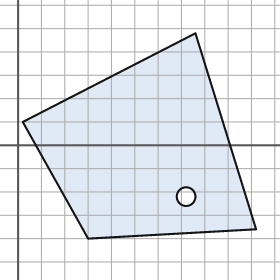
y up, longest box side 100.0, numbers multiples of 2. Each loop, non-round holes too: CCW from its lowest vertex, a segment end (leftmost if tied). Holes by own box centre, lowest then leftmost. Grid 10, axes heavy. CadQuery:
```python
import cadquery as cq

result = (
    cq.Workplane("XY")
    .moveTo(30.0, -40.0)
    .lineTo(102.0, -36.0)
    .lineTo(76.0, 48.0)
    .lineTo(2.0, 10.0)
    .close()
    .moveTo(72.0, -22.0)
    .circle(4.0)
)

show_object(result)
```